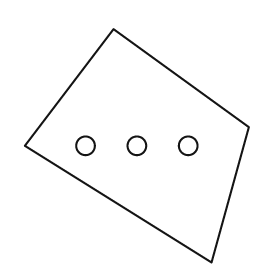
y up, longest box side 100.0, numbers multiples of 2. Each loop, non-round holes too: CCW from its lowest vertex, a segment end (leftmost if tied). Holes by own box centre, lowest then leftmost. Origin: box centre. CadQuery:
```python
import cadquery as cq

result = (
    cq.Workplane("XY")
    .moveTo(32.0, -50.0)
    .lineTo(48.0, 8.0)
    .lineTo(-10.0, 50.0)
    .lineTo(-48.0, 0.0)
    .close()
    .moveTo(-22.0, 0.0)
    .circle(4.0)
    .moveTo(0.0, 0.0)
    .circle(4.0)
    .moveTo(22.0, 0.0)
    .circle(4.0)
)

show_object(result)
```